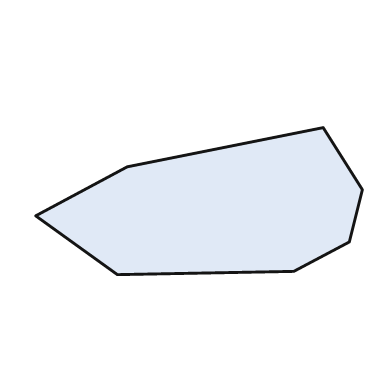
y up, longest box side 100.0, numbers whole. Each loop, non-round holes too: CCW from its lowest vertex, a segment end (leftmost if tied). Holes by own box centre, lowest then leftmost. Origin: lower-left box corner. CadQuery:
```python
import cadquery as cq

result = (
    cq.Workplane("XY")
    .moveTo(25.0, 0.0)
    .lineTo(79.0, 1.0)
    .lineTo(96.0, 10.0)
    .lineTo(100.0, 26.0)
    .lineTo(88.0, 45.0)
    .lineTo(28.0, 33.0)
    .lineTo(0.0, 18.0)
    .close()
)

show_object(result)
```